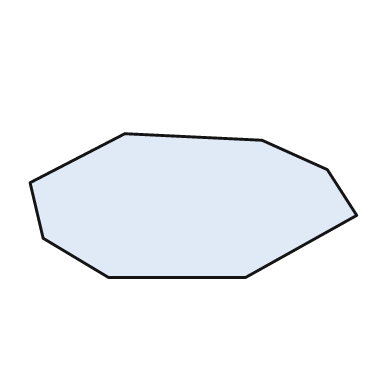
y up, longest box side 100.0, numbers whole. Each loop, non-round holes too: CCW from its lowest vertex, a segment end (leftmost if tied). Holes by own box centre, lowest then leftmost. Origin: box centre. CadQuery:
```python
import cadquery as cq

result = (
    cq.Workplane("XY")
    .moveTo(-26.0, -22.0)
    .lineTo(16.0, -22.0)
    .lineTo(50.0, -3.0)
    .lineTo(41.0, 11.0)
    .lineTo(21.0, 20.0)
    .lineTo(-21.0, 22.0)
    .lineTo(-50.0, 7.0)
    .lineTo(-46.0, -10.0)
    .close()
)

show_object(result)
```